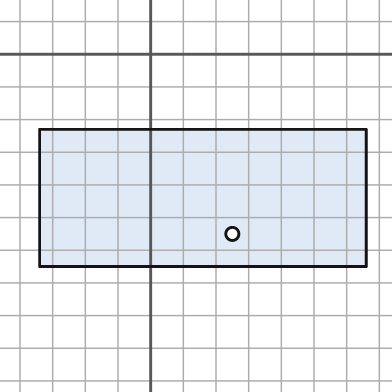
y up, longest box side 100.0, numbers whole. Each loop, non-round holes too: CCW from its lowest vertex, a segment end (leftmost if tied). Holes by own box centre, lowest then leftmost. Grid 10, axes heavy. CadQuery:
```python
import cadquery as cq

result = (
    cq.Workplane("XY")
    .moveTo(-34.0, -65.0)
    .lineTo(66.0, -65.0)
    .lineTo(66.0, -23.0)
    .lineTo(-34.0, -23.0)
    .close()
    .moveTo(25.0, -55.0)
    .circle(2.0)
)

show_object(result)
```